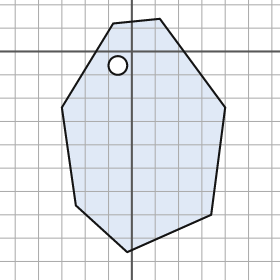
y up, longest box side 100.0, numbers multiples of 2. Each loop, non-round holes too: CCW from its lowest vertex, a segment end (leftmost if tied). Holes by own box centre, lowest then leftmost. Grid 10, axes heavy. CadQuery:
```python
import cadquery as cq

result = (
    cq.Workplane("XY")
    .moveTo(-2.0, -86.0)
    .lineTo(34.0, -70.0)
    .lineTo(40.0, -24.0)
    .lineTo(12.0, 14.0)
    .lineTo(-8.0, 12.0)
    .lineTo(-30.0, -24.0)
    .lineTo(-24.0, -66.0)
    .close()
    .moveTo(-6.0, -6.0)
    .circle(4.0)
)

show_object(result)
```